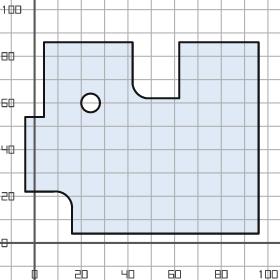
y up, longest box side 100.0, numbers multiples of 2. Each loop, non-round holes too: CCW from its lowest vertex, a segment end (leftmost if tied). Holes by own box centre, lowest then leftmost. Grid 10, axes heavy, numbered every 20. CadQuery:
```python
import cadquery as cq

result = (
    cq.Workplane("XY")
    .moveTo(16.0, 4.0)
    .lineTo(96.0, 4.0)
    .lineTo(96.0, 86.0)
    .lineTo(62.0, 86.0)
    .lineTo(62.0, 62.0)
    .lineTo(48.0, 62.0)
    .threePointArc((44.0, 64.0), (42.0, 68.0))
    .lineTo(42.0, 86.0)
    .lineTo(4.0, 86.0)
    .lineTo(4.0, 54.0)
    .lineTo(-4.0, 54.0)
    .lineTo(-4.0, 22.0)
    .lineTo(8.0, 22.0)
    .threePointArc((14.0, 20.0), (16.0, 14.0))
    .close()
    .moveTo(24.0, 60.0)
    .circle(4.0)
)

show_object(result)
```